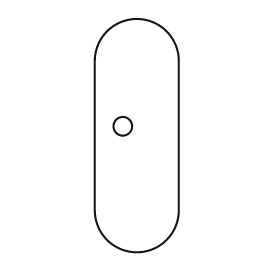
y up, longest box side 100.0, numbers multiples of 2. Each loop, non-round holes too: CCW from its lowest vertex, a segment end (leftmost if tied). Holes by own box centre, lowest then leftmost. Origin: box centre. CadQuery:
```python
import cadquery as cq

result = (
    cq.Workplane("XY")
    .moveTo(-18.0, -32.0)
    .threePointArc((0.0, -50.0), (18.0, -32.0))
    .lineTo(18.0, 32.0)
    .threePointArc((0.0, 50.0), (-18.0, 32.0))
    .close()
    .moveTo(-6.0, 4.0)
    .circle(4.0)
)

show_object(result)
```